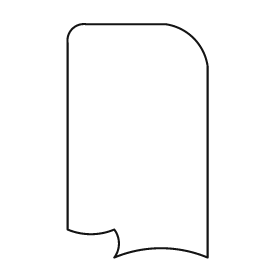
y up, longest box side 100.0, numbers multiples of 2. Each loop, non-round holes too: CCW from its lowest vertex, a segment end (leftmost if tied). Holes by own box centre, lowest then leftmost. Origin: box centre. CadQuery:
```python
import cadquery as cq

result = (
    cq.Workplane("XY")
    .moveTo(-10.0, -50.0)
    .threePointArc((10.0, -46.0), (30.0, -50.0))
    .lineTo(30.0, 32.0)
    .threePointArc((24.0, 44.0), (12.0, 50.0))
    .lineTo(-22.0, 50.0)
    .threePointArc((-28.0, 48.0), (-30.0, 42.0))
    .lineTo(-30.0, -38.0)
    .threePointArc((-20.0, -40.0), (-10.0, -38.0))
    .threePointArc((-8.0, -44.0), (-10.0, -50.0))
    .close()
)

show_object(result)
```